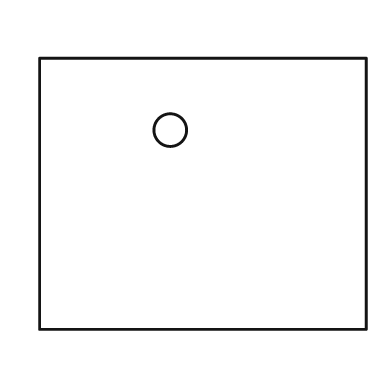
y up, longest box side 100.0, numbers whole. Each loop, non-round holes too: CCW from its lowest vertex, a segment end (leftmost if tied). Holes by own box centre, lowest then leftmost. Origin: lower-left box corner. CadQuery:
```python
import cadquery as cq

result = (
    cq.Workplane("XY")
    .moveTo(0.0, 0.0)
    .lineTo(100.0, 0.0)
    .lineTo(100.0, 83.0)
    .lineTo(0.0, 83.0)
    .close()
    .moveTo(40.0, 61.0)
    .circle(5.0)
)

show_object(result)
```